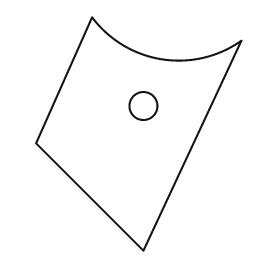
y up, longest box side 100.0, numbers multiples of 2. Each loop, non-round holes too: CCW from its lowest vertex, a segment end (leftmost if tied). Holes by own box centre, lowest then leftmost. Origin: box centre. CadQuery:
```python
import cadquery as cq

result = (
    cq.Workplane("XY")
    .moveTo(2.0, -50.0)
    .lineTo(44.0, 40.0)
    .threePointArc((10.0, 32.0), (-20.0, 50.0))
    .lineTo(-44.0, -4.0)
    .close()
    .moveTo(2.0, 12.0)
    .circle(6.0)
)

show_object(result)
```